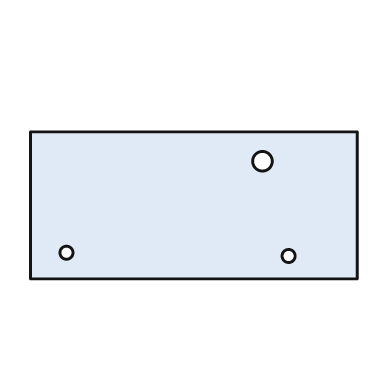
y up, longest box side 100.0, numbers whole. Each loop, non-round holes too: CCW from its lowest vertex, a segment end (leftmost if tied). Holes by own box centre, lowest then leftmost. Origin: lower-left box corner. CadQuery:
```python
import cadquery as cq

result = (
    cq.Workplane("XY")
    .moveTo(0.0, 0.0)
    .lineTo(100.0, 0.0)
    .lineTo(100.0, 45.0)
    .lineTo(0.0, 45.0)
    .close()
    .moveTo(79.0, 7.0)
    .circle(2.0)
    .moveTo(11.0, 8.0)
    .circle(2.0)
    .moveTo(71.0, 36.0)
    .circle(3.0)
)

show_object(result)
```